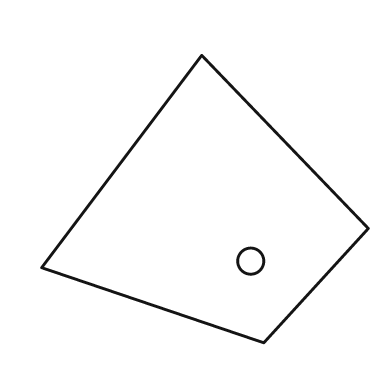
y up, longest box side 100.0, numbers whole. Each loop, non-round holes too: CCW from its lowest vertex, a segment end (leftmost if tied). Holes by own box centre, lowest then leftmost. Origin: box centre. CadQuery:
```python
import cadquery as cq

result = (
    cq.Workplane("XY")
    .moveTo(18.0, -44.0)
    .lineTo(50.0, -9.0)
    .lineTo(-1.0, 44.0)
    .lineTo(-50.0, -21.0)
    .close()
    .moveTo(14.0, -19.0)
    .circle(4.0)
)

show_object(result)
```